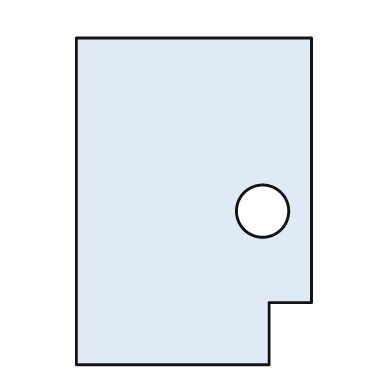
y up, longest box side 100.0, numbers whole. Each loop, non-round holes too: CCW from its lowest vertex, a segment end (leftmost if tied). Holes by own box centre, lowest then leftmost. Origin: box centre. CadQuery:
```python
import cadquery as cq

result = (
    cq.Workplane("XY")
    .moveTo(-36.0, -50.0)
    .lineTo(23.0, -50.0)
    .lineTo(23.0, -31.0)
    .lineTo(36.0, -31.0)
    .lineTo(36.0, 50.0)
    .lineTo(-36.0, 50.0)
    .close()
    .moveTo(21.0, -3.0)
    .circle(8.0)
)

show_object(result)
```